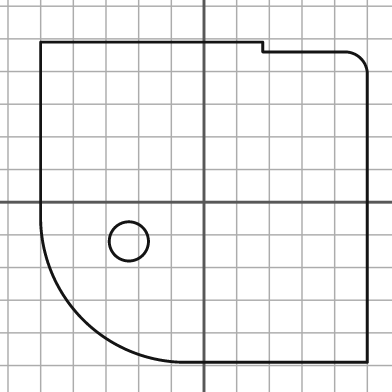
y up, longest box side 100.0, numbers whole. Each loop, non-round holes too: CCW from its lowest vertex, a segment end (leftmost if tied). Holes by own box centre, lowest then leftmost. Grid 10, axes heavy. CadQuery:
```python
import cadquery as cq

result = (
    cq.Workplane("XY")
    .moveTo(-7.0, -49.0)
    .lineTo(50.0, -49.0)
    .lineTo(50.0, 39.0)
    .threePointArc((48.0, 44.0), (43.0, 46.0))
    .lineTo(18.0, 46.0)
    .lineTo(18.0, 49.0)
    .lineTo(-50.0, 49.0)
    .lineTo(-50.0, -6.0)
    .threePointArc((-37.0, -36.0), (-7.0, -49.0))
    .close()
    .moveTo(-23.0, -12.0)
    .circle(6.0)
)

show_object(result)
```